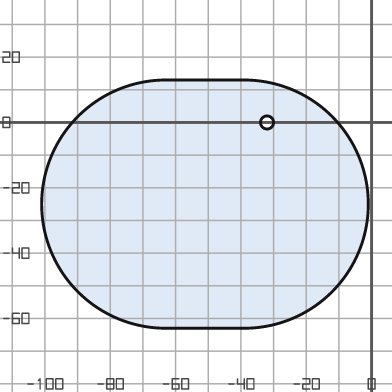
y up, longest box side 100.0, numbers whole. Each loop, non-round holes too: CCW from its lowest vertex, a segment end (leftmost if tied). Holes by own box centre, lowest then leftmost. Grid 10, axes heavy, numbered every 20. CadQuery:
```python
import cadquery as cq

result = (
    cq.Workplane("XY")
    .moveTo(-63.0, -63.0)
    .lineTo(-39.0, -63.0)
    .threePointArc((-1.0, -25.0), (-39.0, 13.0))
    .lineTo(-63.0, 13.0)
    .threePointArc((-101.0, -25.0), (-63.0, -63.0))
    .close()
    .moveTo(-32.0, 0.0)
    .circle(2.0)
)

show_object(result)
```